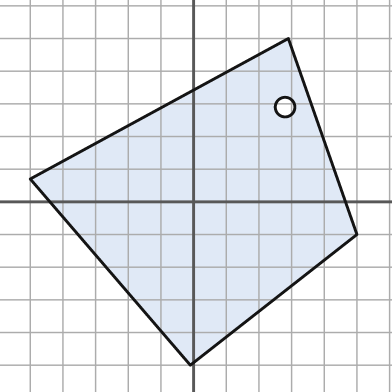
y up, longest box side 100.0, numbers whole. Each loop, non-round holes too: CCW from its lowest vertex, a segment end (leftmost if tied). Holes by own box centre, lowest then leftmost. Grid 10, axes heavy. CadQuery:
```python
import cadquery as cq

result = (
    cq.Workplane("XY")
    .moveTo(-1.0, -50.0)
    .lineTo(50.0, -10.0)
    .lineTo(29.0, 50.0)
    .lineTo(-50.0, 7.0)
    .close()
    .moveTo(28.0, 29.0)
    .circle(3.0)
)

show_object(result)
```